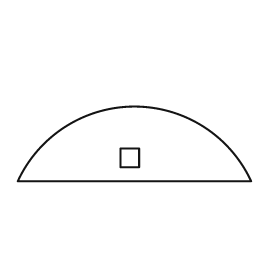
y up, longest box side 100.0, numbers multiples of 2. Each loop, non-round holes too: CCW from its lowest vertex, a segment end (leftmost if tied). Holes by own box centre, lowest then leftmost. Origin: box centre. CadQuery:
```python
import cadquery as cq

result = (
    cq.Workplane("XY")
    .moveTo(-50.0, -16.0)
    .lineTo(50.0, -16.0)
    .threePointArc((0.0, 16.0), (-50.0, -16.0))
    .close()
    .moveTo(-6.0, -10.0)
    .lineTo(2.0, -10.0)
    .lineTo(2.0, -2.0)
    .lineTo(-6.0, -2.0)
    .close()
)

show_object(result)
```